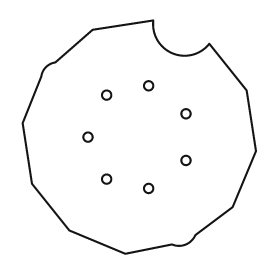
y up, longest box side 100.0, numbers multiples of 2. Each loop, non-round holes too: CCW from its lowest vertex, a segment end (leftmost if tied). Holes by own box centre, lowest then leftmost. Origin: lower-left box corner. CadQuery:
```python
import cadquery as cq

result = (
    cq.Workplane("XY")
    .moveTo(44.0, 0.0)
    .lineTo(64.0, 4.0)
    .threePointArc((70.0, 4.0), (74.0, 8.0))
    .lineTo(90.0, 20.0)
    .lineTo(100.0, 44.0)
    .lineTo(96.0, 70.0)
    .lineTo(80.0, 90.0)
    .threePointArc((64.0, 86.0), (56.0, 100.0))
    .lineTo(30.0, 96.0)
    .lineTo(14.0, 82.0)
    .threePointArc((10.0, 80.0), (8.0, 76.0))
    .lineTo(0.0, 56.0)
    .lineTo(4.0, 30.0)
    .lineTo(20.0, 10.0)
    .close()
    .moveTo(54.0, 28.0)
    .circle(2.0)
    .moveTo(36.0, 32.0)
    .circle(2.0)
    .moveTo(70.0, 40.0)
    .circle(2.0)
    .moveTo(28.0, 50.0)
    .circle(2.0)
    .moveTo(70.0, 60.0)
    .circle(2.0)
    .moveTo(36.0, 68.0)
    .circle(2.0)
    .moveTo(54.0, 72.0)
    .circle(2.0)
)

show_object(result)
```